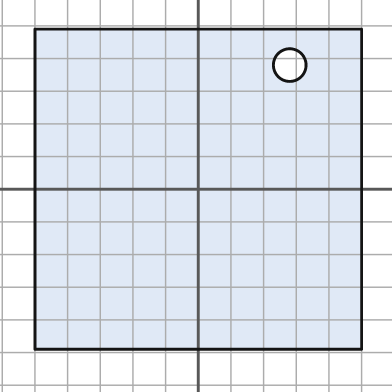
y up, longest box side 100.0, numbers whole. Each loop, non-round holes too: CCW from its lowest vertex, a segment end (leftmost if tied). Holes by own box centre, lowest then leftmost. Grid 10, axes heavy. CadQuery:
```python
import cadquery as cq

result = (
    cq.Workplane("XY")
    .moveTo(-50.0, -49.0)
    .lineTo(50.0, -49.0)
    .lineTo(50.0, 49.0)
    .lineTo(-50.0, 49.0)
    .close()
    .moveTo(28.0, 38.0)
    .circle(5.0)
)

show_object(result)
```